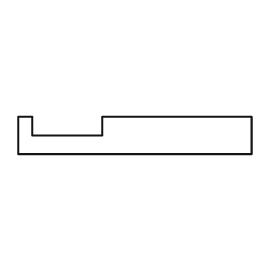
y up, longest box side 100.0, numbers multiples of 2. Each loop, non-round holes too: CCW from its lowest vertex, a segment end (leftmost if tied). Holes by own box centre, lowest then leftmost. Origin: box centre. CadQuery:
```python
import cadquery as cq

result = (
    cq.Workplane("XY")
    .moveTo(-50.0, -8.0)
    .lineTo(50.0, -8.0)
    .lineTo(50.0, 8.0)
    .lineTo(-14.0, 8.0)
    .lineTo(-14.0, 0.0)
    .lineTo(-44.0, 0.0)
    .lineTo(-44.0, 8.0)
    .lineTo(-50.0, 8.0)
    .close()
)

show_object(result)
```